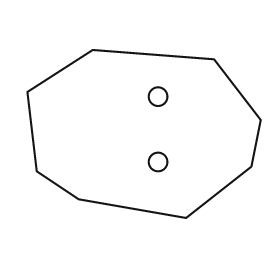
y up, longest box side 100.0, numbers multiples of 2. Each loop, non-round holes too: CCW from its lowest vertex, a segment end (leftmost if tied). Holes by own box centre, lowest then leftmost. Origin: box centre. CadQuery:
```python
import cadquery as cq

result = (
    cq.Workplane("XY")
    .moveTo(18.0, -36.0)
    .lineTo(46.0, -14.0)
    .lineTo(50.0, 6.0)
    .lineTo(30.0, 32.0)
    .lineTo(-22.0, 36.0)
    .lineTo(-50.0, 18.0)
    .lineTo(-46.0, -16.0)
    .lineTo(-28.0, -28.0)
    .close()
    .moveTo(6.0, -12.0)
    .circle(4.0)
    .moveTo(6.0, 16.0)
    .circle(4.0)
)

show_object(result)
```